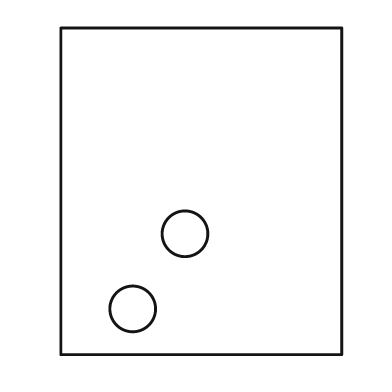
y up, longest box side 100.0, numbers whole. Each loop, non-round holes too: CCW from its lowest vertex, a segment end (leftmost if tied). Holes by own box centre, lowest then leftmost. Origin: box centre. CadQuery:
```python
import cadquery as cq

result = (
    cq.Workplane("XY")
    .moveTo(-43.0, -50.0)
    .lineTo(43.0, -50.0)
    .lineTo(43.0, 50.0)
    .lineTo(-43.0, 50.0)
    .close()
    .moveTo(-21.0, -36.0)
    .circle(7.0)
    .moveTo(-5.0, -13.0)
    .circle(7.0)
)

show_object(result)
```